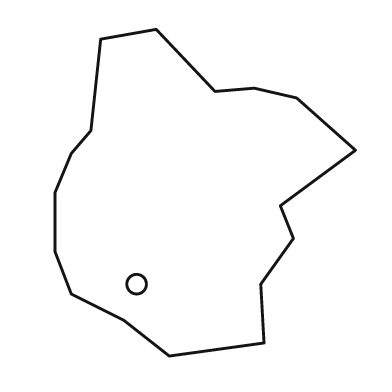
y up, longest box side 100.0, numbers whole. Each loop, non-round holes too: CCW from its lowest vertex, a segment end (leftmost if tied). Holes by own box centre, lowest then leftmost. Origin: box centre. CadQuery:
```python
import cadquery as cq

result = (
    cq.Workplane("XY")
    .moveTo(-11.0, -50.0)
    .lineTo(18.0, -46.0)
    .lineTo(17.0, -28.0)
    .lineTo(27.0, -14.0)
    .lineTo(23.0, -4.0)
    .lineTo(46.0, 13.0)
    .lineTo(28.0, 29.0)
    .lineTo(15.0, 32.0)
    .lineTo(3.0, 31.0)
    .lineTo(-15.0, 50.0)
    .lineTo(-32.0, 47.0)
    .lineTo(-35.0, 19.0)
    .lineTo(-41.0, 12.0)
    .lineTo(-46.0, 0.0)
    .lineTo(-46.0, -18.0)
    .lineTo(-41.0, -31.0)
    .lineTo(-25.0, -39.0)
    .close()
    .moveTo(-21.0, -28.0)
    .circle(3.0)
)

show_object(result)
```